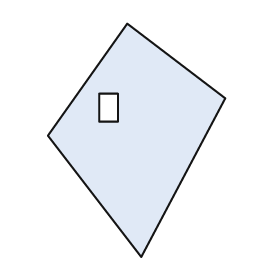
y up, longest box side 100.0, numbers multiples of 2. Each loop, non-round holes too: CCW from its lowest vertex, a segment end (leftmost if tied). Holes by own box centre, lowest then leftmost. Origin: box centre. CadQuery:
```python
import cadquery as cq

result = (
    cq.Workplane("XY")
    .moveTo(2.0, -50.0)
    .lineTo(38.0, 18.0)
    .lineTo(-4.0, 50.0)
    .lineTo(-38.0, 2.0)
    .close()
    .moveTo(-16.0, 8.0)
    .lineTo(-8.0, 8.0)
    .lineTo(-8.0, 20.0)
    .lineTo(-16.0, 20.0)
    .close()
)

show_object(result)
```